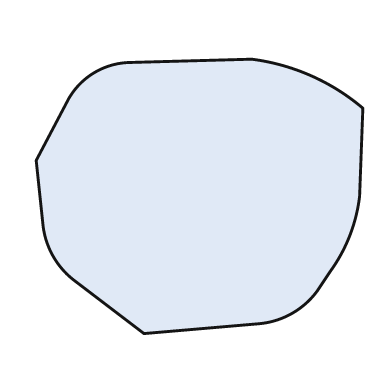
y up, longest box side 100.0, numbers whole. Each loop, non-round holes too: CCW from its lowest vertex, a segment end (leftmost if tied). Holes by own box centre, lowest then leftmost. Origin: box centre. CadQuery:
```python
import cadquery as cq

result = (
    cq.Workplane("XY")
    .moveTo(-17.0, -42.0)
    .lineTo(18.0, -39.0)
    .threePointArc((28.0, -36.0), (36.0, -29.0))
    .lineTo(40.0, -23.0)
    .threePointArc((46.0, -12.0), (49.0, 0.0))
    .lineTo(50.0, 27.0)
    .threePointArc((34.0, 37.0), (16.0, 42.0))
    .lineTo(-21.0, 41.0)
    .threePointArc((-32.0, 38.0), (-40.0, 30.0))
    .lineTo(-50.0, 11.0)
    .lineTo(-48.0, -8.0)
    .threePointArc((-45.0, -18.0), (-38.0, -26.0))
    .close()
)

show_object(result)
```